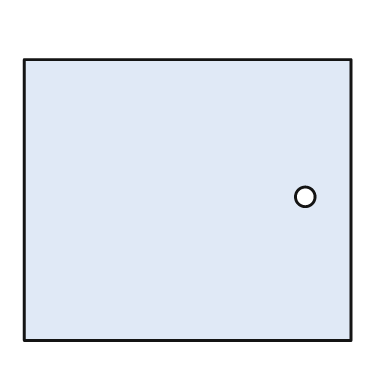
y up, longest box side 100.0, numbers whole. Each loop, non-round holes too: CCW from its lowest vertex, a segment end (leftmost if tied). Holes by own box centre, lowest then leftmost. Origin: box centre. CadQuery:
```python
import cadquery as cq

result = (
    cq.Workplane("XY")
    .moveTo(-50.0, -43.0)
    .lineTo(50.0, -43.0)
    .lineTo(50.0, 43.0)
    .lineTo(-50.0, 43.0)
    .close()
    .moveTo(36.0, 1.0)
    .circle(3.0)
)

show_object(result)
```